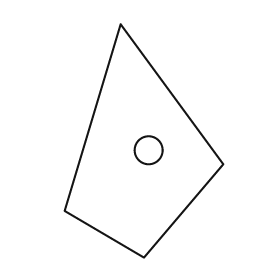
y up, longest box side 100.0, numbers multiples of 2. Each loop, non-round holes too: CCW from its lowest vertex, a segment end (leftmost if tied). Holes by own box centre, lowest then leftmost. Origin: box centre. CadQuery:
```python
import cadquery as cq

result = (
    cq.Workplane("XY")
    .moveTo(0.0, -50.0)
    .lineTo(34.0, -10.0)
    .lineTo(-10.0, 50.0)
    .lineTo(-34.0, -30.0)
    .close()
    .moveTo(2.0, -4.0)
    .circle(6.0)
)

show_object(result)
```